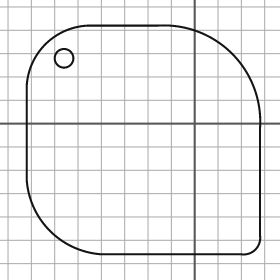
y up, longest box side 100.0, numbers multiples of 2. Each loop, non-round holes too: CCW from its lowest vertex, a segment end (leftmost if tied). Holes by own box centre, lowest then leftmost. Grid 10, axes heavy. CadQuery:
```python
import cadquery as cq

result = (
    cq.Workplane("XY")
    .moveTo(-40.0, -56.0)
    .lineTo(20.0, -56.0)
    .threePointArc((26.0, -54.0), (28.0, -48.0))
    .lineTo(28.0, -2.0)
    .threePointArc((16.0, 30.0), (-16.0, 42.0))
    .lineTo(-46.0, 42.0)
    .threePointArc((-64.0, 34.0), (-72.0, 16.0))
    .lineTo(-72.0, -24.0)
    .threePointArc((-62.0, -46.0), (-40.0, -56.0))
    .close()
    .moveTo(-56.0, 28.0)
    .circle(4.0)
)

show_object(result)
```